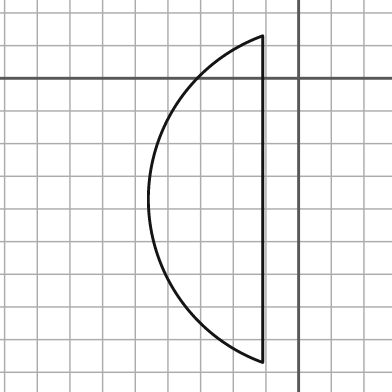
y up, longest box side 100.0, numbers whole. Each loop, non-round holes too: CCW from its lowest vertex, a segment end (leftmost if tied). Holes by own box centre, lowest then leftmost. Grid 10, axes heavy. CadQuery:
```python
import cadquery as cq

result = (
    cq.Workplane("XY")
    .moveTo(-11.0, -87.0)
    .lineTo(-11.0, 13.0)
    .threePointArc((-46.0, -37.0), (-11.0, -87.0))
    .close()
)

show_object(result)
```